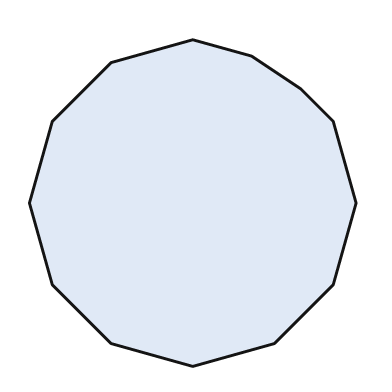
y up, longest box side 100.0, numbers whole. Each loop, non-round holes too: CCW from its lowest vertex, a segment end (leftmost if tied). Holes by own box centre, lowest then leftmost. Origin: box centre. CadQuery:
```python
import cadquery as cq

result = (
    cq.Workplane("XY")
    .moveTo(0.0, -50.0)
    .lineTo(25.0, -43.0)
    .lineTo(43.0, -25.0)
    .lineTo(50.0, 0.0)
    .lineTo(43.0, 25.0)
    .lineTo(33.0, 35.0)
    .lineTo(18.0, 45.0)
    .lineTo(0.0, 50.0)
    .lineTo(-25.0, 43.0)
    .lineTo(-43.0, 25.0)
    .lineTo(-50.0, 0.0)
    .lineTo(-43.0, -25.0)
    .lineTo(-25.0, -43.0)
    .close()
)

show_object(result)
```